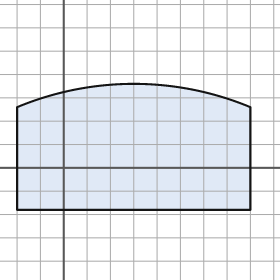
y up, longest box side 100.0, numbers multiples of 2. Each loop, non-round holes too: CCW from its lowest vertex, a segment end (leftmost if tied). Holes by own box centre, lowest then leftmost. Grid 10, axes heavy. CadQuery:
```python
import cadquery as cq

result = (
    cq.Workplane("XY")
    .moveTo(-20.0, -18.0)
    .lineTo(80.0, -18.0)
    .lineTo(80.0, 26.0)
    .threePointArc((30.0, 36.0), (-20.0, 26.0))
    .close()
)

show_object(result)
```